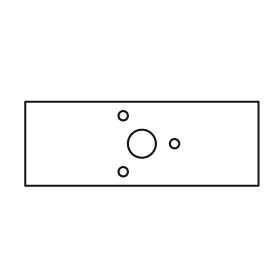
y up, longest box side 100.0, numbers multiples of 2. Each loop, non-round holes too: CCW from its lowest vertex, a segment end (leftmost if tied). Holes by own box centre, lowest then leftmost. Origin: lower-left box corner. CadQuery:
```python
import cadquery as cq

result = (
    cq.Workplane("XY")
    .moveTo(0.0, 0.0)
    .lineTo(100.0, 0.0)
    .lineTo(100.0, 36.0)
    .lineTo(0.0, 36.0)
    .close()
    .moveTo(42.0, 6.0)
    .circle(2.0)
    .moveTo(50.0, 18.0)
    .circle(6.0)
    .moveTo(64.0, 18.0)
    .circle(2.0)
    .moveTo(42.0, 30.0)
    .circle(2.0)
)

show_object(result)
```